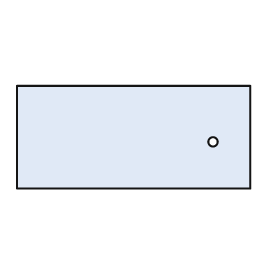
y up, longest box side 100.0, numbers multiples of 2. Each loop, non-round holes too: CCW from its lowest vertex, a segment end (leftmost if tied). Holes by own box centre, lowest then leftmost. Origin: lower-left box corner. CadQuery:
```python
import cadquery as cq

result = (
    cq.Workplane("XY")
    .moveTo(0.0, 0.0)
    .lineTo(100.0, 0.0)
    .lineTo(100.0, 44.0)
    .lineTo(0.0, 44.0)
    .close()
    .moveTo(84.0, 20.0)
    .circle(2.0)
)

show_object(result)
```